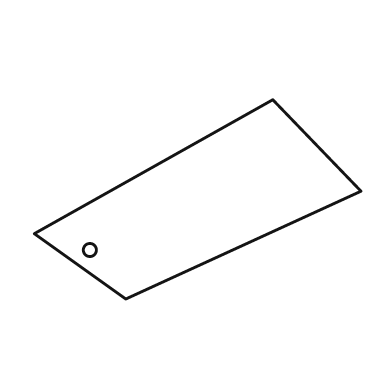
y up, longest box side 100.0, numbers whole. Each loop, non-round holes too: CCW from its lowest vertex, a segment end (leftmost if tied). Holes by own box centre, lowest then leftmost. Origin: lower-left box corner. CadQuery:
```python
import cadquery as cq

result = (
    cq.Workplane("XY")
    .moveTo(28.0, 0.0)
    .lineTo(100.0, 33.0)
    .lineTo(73.0, 61.0)
    .lineTo(0.0, 20.0)
    .close()
    .moveTo(17.0, 15.0)
    .circle(2.0)
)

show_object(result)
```